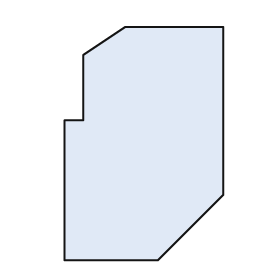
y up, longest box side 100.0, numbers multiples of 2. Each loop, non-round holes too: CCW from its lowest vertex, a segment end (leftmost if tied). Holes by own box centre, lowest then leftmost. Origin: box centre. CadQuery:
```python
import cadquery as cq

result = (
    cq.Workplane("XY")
    .moveTo(-34.0, -50.0)
    .lineTo(6.0, -50.0)
    .lineTo(34.0, -22.0)
    .lineTo(34.0, 50.0)
    .lineTo(-8.0, 50.0)
    .lineTo(-26.0, 38.0)
    .lineTo(-26.0, 10.0)
    .lineTo(-34.0, 10.0)
    .close()
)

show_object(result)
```